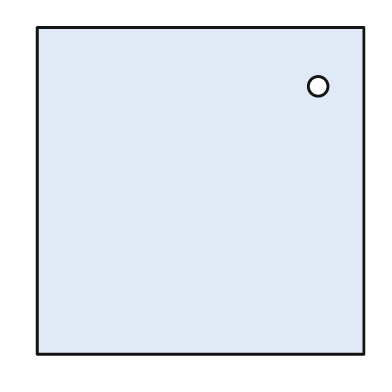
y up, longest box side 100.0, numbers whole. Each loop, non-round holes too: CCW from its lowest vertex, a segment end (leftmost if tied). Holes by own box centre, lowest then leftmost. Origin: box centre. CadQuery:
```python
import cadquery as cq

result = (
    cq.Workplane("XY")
    .moveTo(-50.0, -50.0)
    .lineTo(50.0, -50.0)
    .lineTo(50.0, 50.0)
    .lineTo(-50.0, 50.0)
    .close()
    .moveTo(36.0, 32.0)
    .circle(3.0)
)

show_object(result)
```